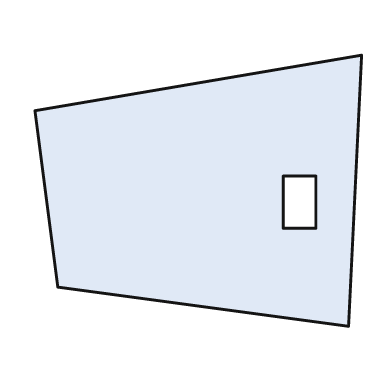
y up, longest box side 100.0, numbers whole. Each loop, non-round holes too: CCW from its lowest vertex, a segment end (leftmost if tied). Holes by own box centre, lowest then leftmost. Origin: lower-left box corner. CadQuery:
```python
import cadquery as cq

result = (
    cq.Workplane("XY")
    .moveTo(96.0, 0.0)
    .lineTo(100.0, 83.0)
    .lineTo(0.0, 66.0)
    .lineTo(7.0, 12.0)
    .close()
    .moveTo(76.0, 30.0)
    .lineTo(86.0, 30.0)
    .lineTo(86.0, 46.0)
    .lineTo(76.0, 46.0)
    .close()
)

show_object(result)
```